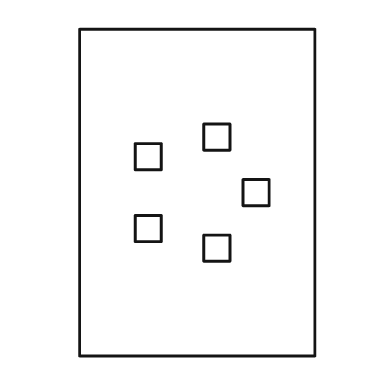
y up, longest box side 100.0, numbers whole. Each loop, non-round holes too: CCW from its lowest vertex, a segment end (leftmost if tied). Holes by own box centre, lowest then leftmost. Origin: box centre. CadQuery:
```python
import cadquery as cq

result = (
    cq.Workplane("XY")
    .moveTo(-36.0, -50.0)
    .lineTo(36.0, -50.0)
    .lineTo(36.0, 50.0)
    .lineTo(-36.0, 50.0)
    .close()
    .moveTo(2.0, -21.0)
    .lineTo(10.0, -21.0)
    .lineTo(10.0, -13.0)
    .lineTo(2.0, -13.0)
    .close()
    .moveTo(-19.0, -15.0)
    .lineTo(-11.0, -15.0)
    .lineTo(-11.0, -7.0)
    .lineTo(-19.0, -7.0)
    .close()
    .moveTo(14.0, -4.0)
    .lineTo(22.0, -4.0)
    .lineTo(22.0, 4.0)
    .lineTo(14.0, 4.0)
    .close()
    .moveTo(-19.0, 7.0)
    .lineTo(-11.0, 7.0)
    .lineTo(-11.0, 15.0)
    .lineTo(-19.0, 15.0)
    .close()
    .moveTo(2.0, 13.0)
    .lineTo(10.0, 13.0)
    .lineTo(10.0, 21.0)
    .lineTo(2.0, 21.0)
    .close()
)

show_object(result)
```